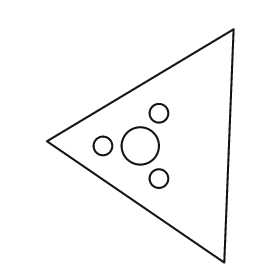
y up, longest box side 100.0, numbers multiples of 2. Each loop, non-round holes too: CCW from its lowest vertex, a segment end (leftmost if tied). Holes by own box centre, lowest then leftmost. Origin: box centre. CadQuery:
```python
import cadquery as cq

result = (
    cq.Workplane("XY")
    .moveTo(36.0, -50.0)
    .lineTo(40.0, 50.0)
    .lineTo(-40.0, 2.0)
    .close()
    .moveTo(8.0, -14.0)
    .circle(4.0)
    .moveTo(-16.0, 0.0)
    .circle(4.0)
    .moveTo(0.0, 0.0)
    .circle(8.0)
    .moveTo(8.0, 14.0)
    .circle(4.0)
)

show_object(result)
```